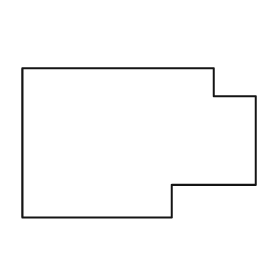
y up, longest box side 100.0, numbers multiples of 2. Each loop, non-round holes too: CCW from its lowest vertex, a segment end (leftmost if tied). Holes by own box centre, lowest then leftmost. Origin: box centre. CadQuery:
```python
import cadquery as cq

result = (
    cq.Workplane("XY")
    .moveTo(-50.0, -32.0)
    .lineTo(14.0, -32.0)
    .lineTo(14.0, -18.0)
    .lineTo(50.0, -18.0)
    .lineTo(50.0, 20.0)
    .lineTo(32.0, 20.0)
    .lineTo(32.0, 32.0)
    .lineTo(-50.0, 32.0)
    .close()
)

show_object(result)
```